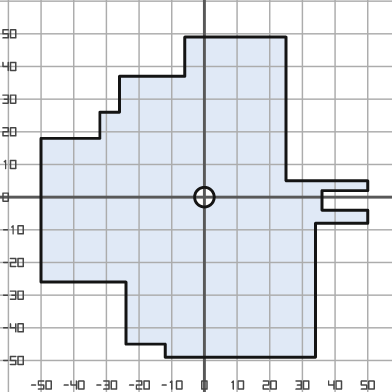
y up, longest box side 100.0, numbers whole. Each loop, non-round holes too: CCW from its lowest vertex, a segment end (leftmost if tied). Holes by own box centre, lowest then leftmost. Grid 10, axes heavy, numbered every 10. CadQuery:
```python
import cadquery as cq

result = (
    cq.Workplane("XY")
    .moveTo(-12.0, -49.0)
    .lineTo(34.0, -49.0)
    .lineTo(34.0, -8.0)
    .lineTo(50.0, -8.0)
    .lineTo(50.0, -4.0)
    .lineTo(36.0, -4.0)
    .lineTo(36.0, 2.0)
    .lineTo(50.0, 2.0)
    .lineTo(50.0, 5.0)
    .lineTo(25.0, 5.0)
    .lineTo(25.0, 49.0)
    .lineTo(-6.0, 49.0)
    .lineTo(-6.0, 37.0)
    .lineTo(-26.0, 37.0)
    .lineTo(-26.0, 26.0)
    .lineTo(-32.0, 26.0)
    .lineTo(-32.0, 18.0)
    .lineTo(-50.0, 18.0)
    .lineTo(-50.0, -26.0)
    .lineTo(-24.0, -26.0)
    .lineTo(-24.0, -45.0)
    .lineTo(-12.0, -45.0)
    .close()
    .moveTo(0.0, 0.0)
    .circle(3.0)
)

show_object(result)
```